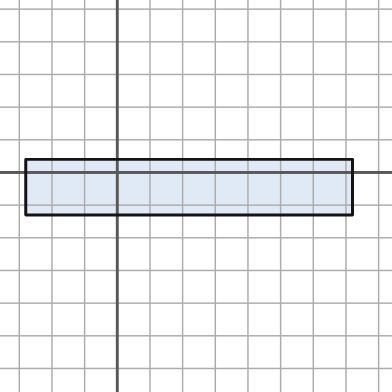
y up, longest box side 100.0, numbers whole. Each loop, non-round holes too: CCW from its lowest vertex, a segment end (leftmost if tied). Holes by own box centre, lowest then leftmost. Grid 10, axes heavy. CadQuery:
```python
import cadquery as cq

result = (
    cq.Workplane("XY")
    .moveTo(-28.0, -13.0)
    .lineTo(72.0, -13.0)
    .lineTo(72.0, 4.0)
    .lineTo(-28.0, 4.0)
    .close()
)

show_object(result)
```